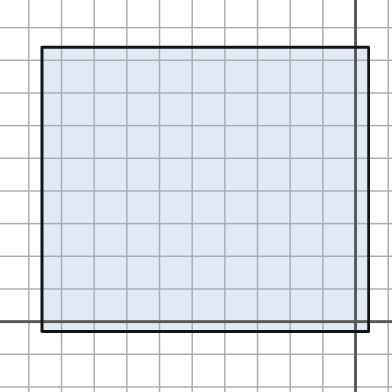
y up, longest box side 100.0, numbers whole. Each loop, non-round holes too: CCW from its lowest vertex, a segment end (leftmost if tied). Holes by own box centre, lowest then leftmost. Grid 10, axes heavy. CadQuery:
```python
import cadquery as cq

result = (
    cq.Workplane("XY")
    .moveTo(-96.0, -3.0)
    .lineTo(4.0, -3.0)
    .lineTo(4.0, 84.0)
    .lineTo(-96.0, 84.0)
    .close()
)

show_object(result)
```